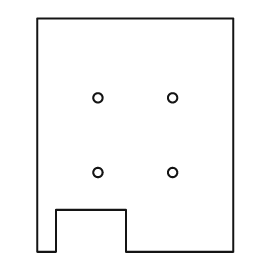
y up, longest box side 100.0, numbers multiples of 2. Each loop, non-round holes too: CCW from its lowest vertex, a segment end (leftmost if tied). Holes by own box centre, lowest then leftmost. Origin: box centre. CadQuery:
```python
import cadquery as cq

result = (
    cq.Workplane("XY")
    .moveTo(-42.0, -50.0)
    .lineTo(-34.0, -50.0)
    .lineTo(-34.0, -32.0)
    .lineTo(-4.0, -32.0)
    .lineTo(-4.0, -50.0)
    .lineTo(42.0, -50.0)
    .lineTo(42.0, 50.0)
    .lineTo(-42.0, 50.0)
    .close()
    .moveTo(-16.0, -16.0)
    .circle(2.0)
    .moveTo(16.0, -16.0)
    .circle(2.0)
    .moveTo(-16.0, 16.0)
    .circle(2.0)
    .moveTo(16.0, 16.0)
    .circle(2.0)
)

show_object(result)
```